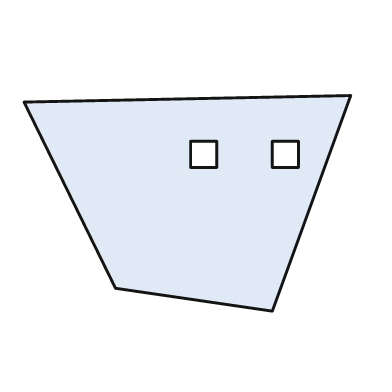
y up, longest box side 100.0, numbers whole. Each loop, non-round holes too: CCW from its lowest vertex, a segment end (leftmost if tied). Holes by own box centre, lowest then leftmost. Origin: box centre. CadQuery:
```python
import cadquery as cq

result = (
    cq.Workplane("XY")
    .moveTo(26.0, -33.0)
    .lineTo(50.0, 33.0)
    .lineTo(-50.0, 31.0)
    .lineTo(-22.0, -26.0)
    .close()
    .moveTo(1.0, 11.0)
    .lineTo(9.0, 11.0)
    .lineTo(9.0, 19.0)
    .lineTo(1.0, 19.0)
    .close()
    .moveTo(26.0, 11.0)
    .lineTo(34.0, 11.0)
    .lineTo(34.0, 19.0)
    .lineTo(26.0, 19.0)
    .close()
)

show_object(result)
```